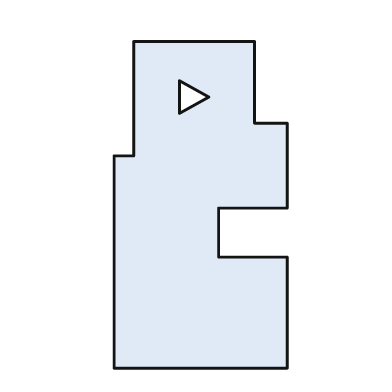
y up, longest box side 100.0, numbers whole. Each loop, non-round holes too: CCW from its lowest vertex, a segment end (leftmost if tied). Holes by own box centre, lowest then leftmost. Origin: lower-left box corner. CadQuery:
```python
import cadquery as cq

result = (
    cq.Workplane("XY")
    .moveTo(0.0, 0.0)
    .lineTo(53.0, 0.0)
    .lineTo(53.0, 34.0)
    .lineTo(32.0, 34.0)
    .lineTo(32.0, 49.0)
    .lineTo(53.0, 49.0)
    .lineTo(53.0, 75.0)
    .lineTo(43.0, 75.0)
    .lineTo(43.0, 100.0)
    .lineTo(6.0, 100.0)
    .lineTo(6.0, 65.0)
    .lineTo(0.0, 65.0)
    .close()
    .moveTo(20.0, 78.0)
    .lineTo(29.0, 83.0)
    .lineTo(20.0, 88.0)
    .close()
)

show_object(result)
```